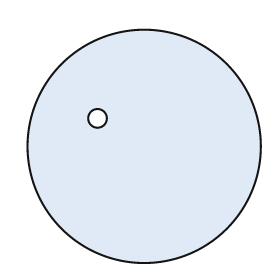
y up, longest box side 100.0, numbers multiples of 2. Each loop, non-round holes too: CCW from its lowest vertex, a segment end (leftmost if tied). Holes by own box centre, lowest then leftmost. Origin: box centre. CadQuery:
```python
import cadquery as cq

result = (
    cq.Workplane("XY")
    .moveTo(0.0, 0.0)
    .circle(50.0)
    .moveTo(-20.0, 12.0)
    .circle(4.0)
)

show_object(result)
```